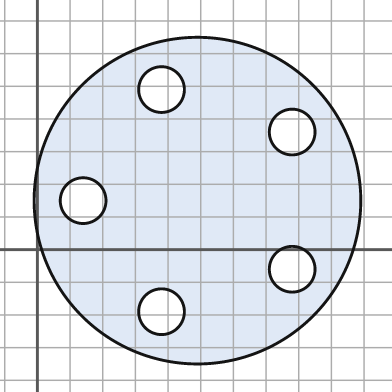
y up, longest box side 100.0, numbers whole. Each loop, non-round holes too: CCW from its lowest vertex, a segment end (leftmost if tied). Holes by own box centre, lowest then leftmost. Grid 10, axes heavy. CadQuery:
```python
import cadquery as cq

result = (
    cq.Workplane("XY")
    .moveTo(49.0, 15.0)
    .circle(50.0)
    .moveTo(38.0, -19.0)
    .circle(7.0)
    .moveTo(78.0, -6.0)
    .circle(7.0)
    .moveTo(14.0, 15.0)
    .circle(7.0)
    .moveTo(78.0, 36.0)
    .circle(7.0)
    .moveTo(38.0, 49.0)
    .circle(7.0)
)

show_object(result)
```